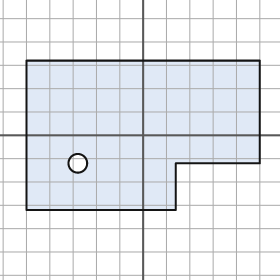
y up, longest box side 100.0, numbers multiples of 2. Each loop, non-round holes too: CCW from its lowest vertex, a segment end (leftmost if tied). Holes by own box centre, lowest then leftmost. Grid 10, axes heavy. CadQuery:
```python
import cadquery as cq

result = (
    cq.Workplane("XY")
    .moveTo(-50.0, -32.0)
    .lineTo(14.0, -32.0)
    .lineTo(14.0, -12.0)
    .lineTo(50.0, -12.0)
    .lineTo(50.0, 32.0)
    .lineTo(-50.0, 32.0)
    .close()
    .moveTo(-28.0, -12.0)
    .circle(4.0)
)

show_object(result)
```